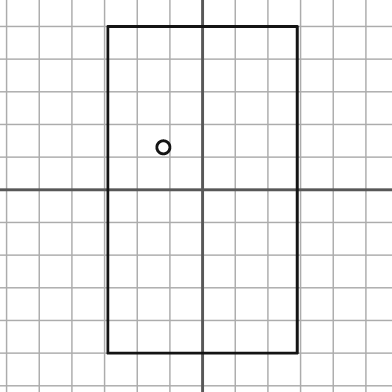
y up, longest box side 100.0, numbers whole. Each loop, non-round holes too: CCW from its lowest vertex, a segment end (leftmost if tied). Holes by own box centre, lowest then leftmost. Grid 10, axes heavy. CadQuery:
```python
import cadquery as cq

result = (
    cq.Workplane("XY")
    .moveTo(-29.0, -50.0)
    .lineTo(29.0, -50.0)
    .lineTo(29.0, 50.0)
    .lineTo(-29.0, 50.0)
    .close()
    .moveTo(-12.0, 13.0)
    .circle(2.0)
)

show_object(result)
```